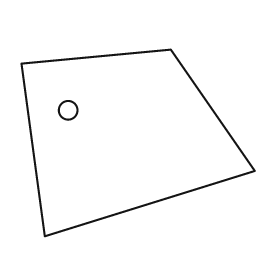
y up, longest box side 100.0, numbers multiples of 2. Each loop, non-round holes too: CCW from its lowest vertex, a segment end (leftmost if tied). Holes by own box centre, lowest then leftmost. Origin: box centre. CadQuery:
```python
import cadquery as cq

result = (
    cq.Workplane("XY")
    .moveTo(-40.0, -40.0)
    .lineTo(50.0, -12.0)
    .lineTo(14.0, 40.0)
    .lineTo(-50.0, 34.0)
    .close()
    .moveTo(-30.0, 14.0)
    .circle(4.0)
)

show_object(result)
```